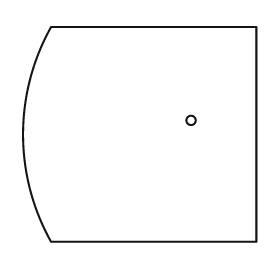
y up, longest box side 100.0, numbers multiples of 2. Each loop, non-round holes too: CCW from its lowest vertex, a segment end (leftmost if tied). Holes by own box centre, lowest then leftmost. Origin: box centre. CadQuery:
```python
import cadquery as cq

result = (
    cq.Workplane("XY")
    .moveTo(-38.0, -46.0)
    .lineTo(50.0, -46.0)
    .lineTo(50.0, 46.0)
    .lineTo(-38.0, 46.0)
    .threePointArc((-50.0, 0.0), (-38.0, -46.0))
    .close()
    .moveTo(22.0, 6.0)
    .circle(2.0)
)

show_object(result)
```